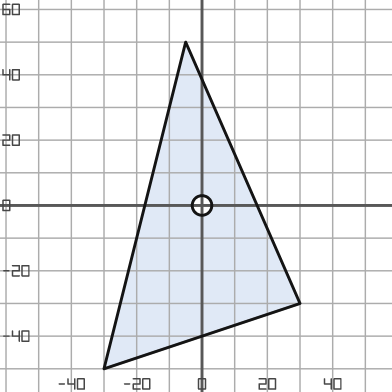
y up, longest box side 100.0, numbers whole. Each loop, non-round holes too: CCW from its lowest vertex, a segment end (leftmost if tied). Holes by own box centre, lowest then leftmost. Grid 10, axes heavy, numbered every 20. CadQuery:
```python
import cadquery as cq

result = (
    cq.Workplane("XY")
    .moveTo(-30.0, -50.0)
    .lineTo(30.0, -30.0)
    .lineTo(-5.0, 50.0)
    .close()
    .moveTo(0.0, 0.0)
    .circle(3.0)
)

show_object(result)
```